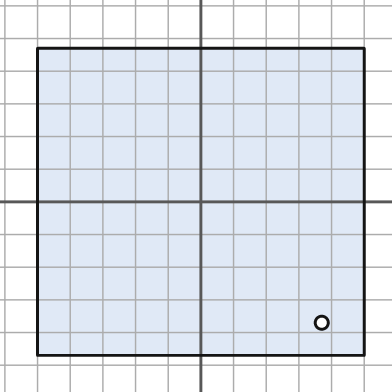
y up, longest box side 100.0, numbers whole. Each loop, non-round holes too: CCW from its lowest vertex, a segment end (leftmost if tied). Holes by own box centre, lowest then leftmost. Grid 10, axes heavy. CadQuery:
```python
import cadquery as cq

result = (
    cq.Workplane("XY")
    .moveTo(-50.0, -47.0)
    .lineTo(50.0, -47.0)
    .lineTo(50.0, 47.0)
    .lineTo(-50.0, 47.0)
    .close()
    .moveTo(37.0, -37.0)
    .circle(2.0)
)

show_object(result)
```